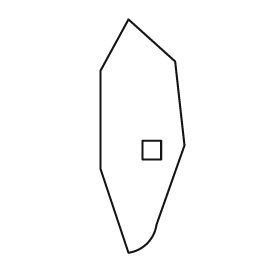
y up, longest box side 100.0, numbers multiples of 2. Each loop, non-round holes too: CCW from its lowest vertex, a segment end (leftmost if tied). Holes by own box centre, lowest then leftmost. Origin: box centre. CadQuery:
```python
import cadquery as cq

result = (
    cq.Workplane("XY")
    .moveTo(-6.0, -50.0)
    .threePointArc((2.0, -46.0), (6.0, -38.0))
    .lineTo(18.0, -4.0)
    .lineTo(14.0, 32.0)
    .lineTo(-6.0, 50.0)
    .lineTo(-18.0, 28.0)
    .lineTo(-18.0, -14.0)
    .close()
    .moveTo(0.0, -10.0)
    .lineTo(8.0, -10.0)
    .lineTo(8.0, -2.0)
    .lineTo(0.0, -2.0)
    .close()
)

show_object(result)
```